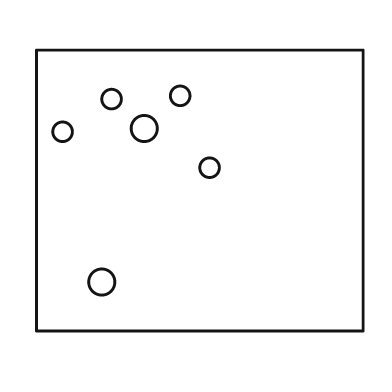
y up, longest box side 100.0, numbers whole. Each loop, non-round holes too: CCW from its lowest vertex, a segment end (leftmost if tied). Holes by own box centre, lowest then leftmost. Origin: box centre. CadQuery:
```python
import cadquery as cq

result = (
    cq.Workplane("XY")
    .moveTo(-50.0, -43.0)
    .lineTo(50.0, -43.0)
    .lineTo(50.0, 43.0)
    .lineTo(-50.0, 43.0)
    .close()
    .moveTo(-30.0, -28.0)
    .circle(4.0)
    .moveTo(3.0, 7.0)
    .circle(3.0)
    .moveTo(-42.0, 18.0)
    .circle(3.0)
    .moveTo(-17.0, 19.0)
    .circle(4.0)
    .moveTo(-27.0, 28.0)
    .circle(3.0)
    .moveTo(-6.0, 29.0)
    .circle(3.0)
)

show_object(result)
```